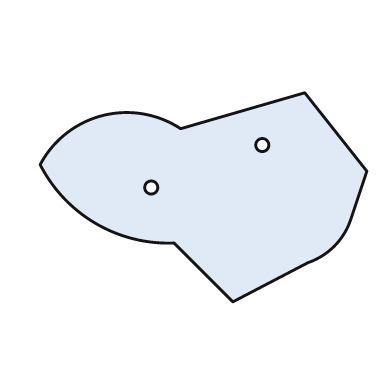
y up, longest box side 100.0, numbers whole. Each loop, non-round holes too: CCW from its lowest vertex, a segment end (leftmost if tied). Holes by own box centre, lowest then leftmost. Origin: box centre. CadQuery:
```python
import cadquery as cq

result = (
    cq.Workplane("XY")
    .moveTo(9.0, -32.0)
    .lineTo(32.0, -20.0)
    .threePointArc((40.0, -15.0), (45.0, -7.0))
    .lineTo(50.0, 8.0)
    .lineTo(31.0, 32.0)
    .lineTo(-7.0, 21.0)
    .threePointArc((-31.0, 25.0), (-50.0, 10.0))
    .threePointArc((-33.0, -8.0), (-9.0, -14.0))
    .close()
    .moveTo(-16.0, 3.0)
    .circle(2.0)
    .moveTo(18.0, 16.0)
    .circle(2.0)
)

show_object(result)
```